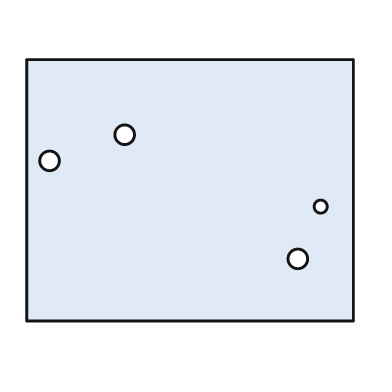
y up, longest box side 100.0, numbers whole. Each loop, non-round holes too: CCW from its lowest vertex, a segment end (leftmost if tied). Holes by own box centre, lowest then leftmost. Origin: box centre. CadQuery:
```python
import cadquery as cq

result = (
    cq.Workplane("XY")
    .moveTo(-50.0, -40.0)
    .lineTo(50.0, -40.0)
    .lineTo(50.0, 40.0)
    .lineTo(-50.0, 40.0)
    .close()
    .moveTo(33.0, -21.0)
    .circle(3.0)
    .moveTo(40.0, -5.0)
    .circle(2.0)
    .moveTo(-43.0, 9.0)
    .circle(3.0)
    .moveTo(-20.0, 17.0)
    .circle(3.0)
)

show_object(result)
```